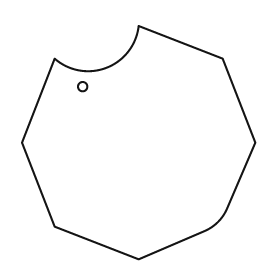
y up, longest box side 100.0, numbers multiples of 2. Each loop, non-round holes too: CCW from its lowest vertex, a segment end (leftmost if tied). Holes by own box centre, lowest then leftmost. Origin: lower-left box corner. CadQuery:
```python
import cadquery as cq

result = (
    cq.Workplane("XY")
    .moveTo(50.0, 0.0)
    .lineTo(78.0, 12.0)
    .threePointArc((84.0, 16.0), (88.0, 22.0))
    .lineTo(100.0, 50.0)
    .lineTo(86.0, 86.0)
    .lineTo(50.0, 100.0)
    .threePointArc((36.0, 82.0), (14.0, 86.0))
    .lineTo(0.0, 50.0)
    .lineTo(14.0, 14.0)
    .close()
    .moveTo(26.0, 74.0)
    .circle(2.0)
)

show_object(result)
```